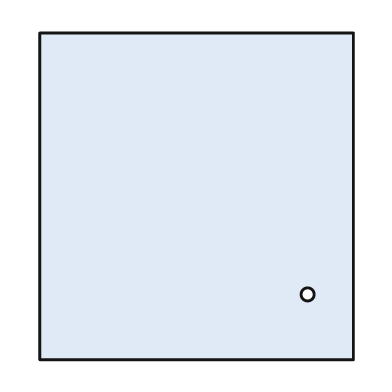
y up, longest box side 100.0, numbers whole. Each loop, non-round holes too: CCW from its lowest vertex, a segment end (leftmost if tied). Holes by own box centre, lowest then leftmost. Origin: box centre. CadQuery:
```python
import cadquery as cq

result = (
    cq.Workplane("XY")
    .moveTo(-48.0, -50.0)
    .lineTo(48.0, -50.0)
    .lineTo(48.0, 50.0)
    .lineTo(-48.0, 50.0)
    .close()
    .moveTo(34.0, -30.0)
    .circle(2.0)
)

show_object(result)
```